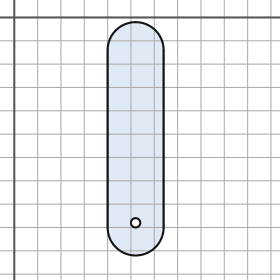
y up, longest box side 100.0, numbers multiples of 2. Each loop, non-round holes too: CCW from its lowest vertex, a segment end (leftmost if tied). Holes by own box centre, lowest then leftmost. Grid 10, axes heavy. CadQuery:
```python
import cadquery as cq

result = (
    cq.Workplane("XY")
    .moveTo(40.0, -90.0)
    .threePointArc((52.0, -102.0), (64.0, -90.0))
    .lineTo(64.0, -14.0)
    .threePointArc((52.0, -2.0), (40.0, -14.0))
    .close()
    .moveTo(52.0, -88.0)
    .circle(2.0)
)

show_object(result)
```